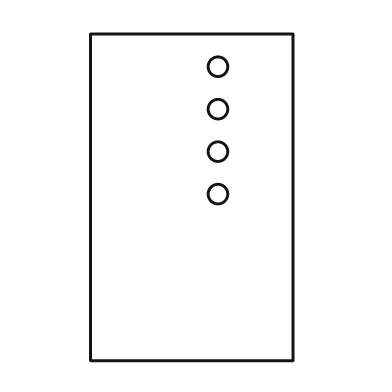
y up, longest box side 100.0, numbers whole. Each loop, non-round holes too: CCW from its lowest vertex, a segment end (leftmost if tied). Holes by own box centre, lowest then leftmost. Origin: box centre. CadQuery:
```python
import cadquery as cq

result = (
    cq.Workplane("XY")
    .moveTo(-31.0, -50.0)
    .lineTo(31.0, -50.0)
    .lineTo(31.0, 50.0)
    .lineTo(-31.0, 50.0)
    .close()
    .moveTo(8.0, 1.0)
    .circle(3.0)
    .moveTo(8.0, 14.0)
    .circle(3.0)
    .moveTo(8.0, 27.0)
    .circle(3.0)
    .moveTo(8.0, 40.0)
    .circle(3.0)
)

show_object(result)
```